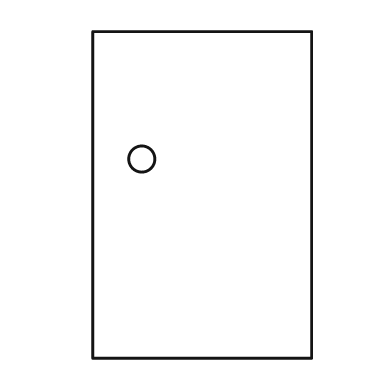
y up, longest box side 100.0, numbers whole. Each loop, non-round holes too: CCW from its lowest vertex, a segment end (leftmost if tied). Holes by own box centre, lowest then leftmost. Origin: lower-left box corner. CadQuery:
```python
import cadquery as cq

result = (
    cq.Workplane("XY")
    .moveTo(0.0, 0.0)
    .lineTo(67.0, 0.0)
    .lineTo(67.0, 100.0)
    .lineTo(0.0, 100.0)
    .close()
    .moveTo(15.0, 61.0)
    .circle(4.0)
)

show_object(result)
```